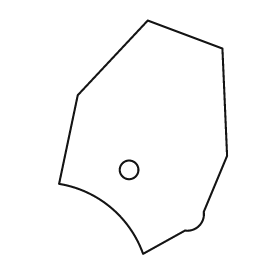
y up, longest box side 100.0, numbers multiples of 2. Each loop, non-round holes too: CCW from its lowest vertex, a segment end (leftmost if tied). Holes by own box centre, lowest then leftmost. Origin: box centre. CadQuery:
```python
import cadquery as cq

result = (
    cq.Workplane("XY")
    .moveTo(0.0, -50.0)
    .lineTo(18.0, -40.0)
    .threePointArc((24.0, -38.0), (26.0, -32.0))
    .lineTo(36.0, -8.0)
    .lineTo(34.0, 38.0)
    .lineTo(2.0, 50.0)
    .lineTo(-28.0, 18.0)
    .lineTo(-36.0, -20.0)
    .threePointArc((-14.0, -30.0), (0.0, -50.0))
    .close()
    .moveTo(-6.0, -14.0)
    .circle(4.0)
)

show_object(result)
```